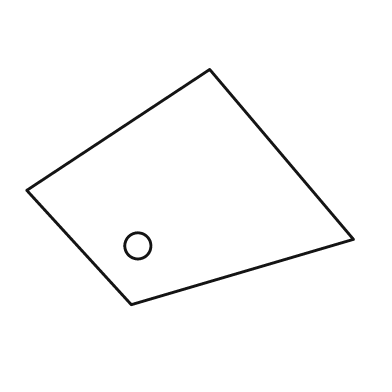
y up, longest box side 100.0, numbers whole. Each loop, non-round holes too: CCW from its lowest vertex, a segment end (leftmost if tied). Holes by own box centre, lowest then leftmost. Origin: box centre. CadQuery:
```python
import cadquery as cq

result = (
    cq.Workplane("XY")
    .moveTo(-18.0, -36.0)
    .lineTo(50.0, -16.0)
    .lineTo(6.0, 36.0)
    .lineTo(-50.0, -1.0)
    .close()
    .moveTo(-16.0, -18.0)
    .circle(4.0)
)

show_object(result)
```